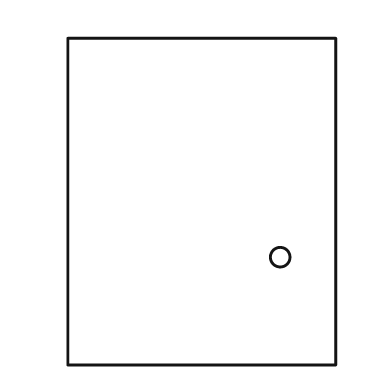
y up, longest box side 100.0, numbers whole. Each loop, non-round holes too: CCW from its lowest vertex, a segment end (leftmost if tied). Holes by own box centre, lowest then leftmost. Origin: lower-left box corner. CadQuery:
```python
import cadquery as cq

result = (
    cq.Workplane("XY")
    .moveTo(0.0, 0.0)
    .lineTo(82.0, 0.0)
    .lineTo(82.0, 100.0)
    .lineTo(0.0, 100.0)
    .close()
    .moveTo(65.0, 33.0)
    .circle(3.0)
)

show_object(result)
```